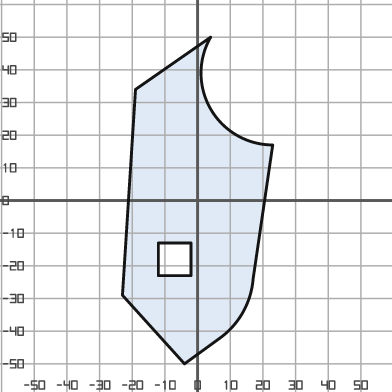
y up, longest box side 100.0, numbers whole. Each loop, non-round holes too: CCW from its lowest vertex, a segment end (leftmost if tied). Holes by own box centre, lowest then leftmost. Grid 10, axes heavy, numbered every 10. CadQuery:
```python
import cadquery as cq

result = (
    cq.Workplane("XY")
    .moveTo(-4.0, -50.0)
    .lineTo(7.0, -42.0)
    .threePointArc((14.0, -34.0), (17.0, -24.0))
    .lineTo(23.0, 17.0)
    .threePointArc((4.0, 28.0), (4.0, 50.0))
    .lineTo(-19.0, 34.0)
    .lineTo(-23.0, -29.0)
    .close()
    .moveTo(-12.0, -23.0)
    .lineTo(-2.0, -23.0)
    .lineTo(-2.0, -13.0)
    .lineTo(-12.0, -13.0)
    .close()
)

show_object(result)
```